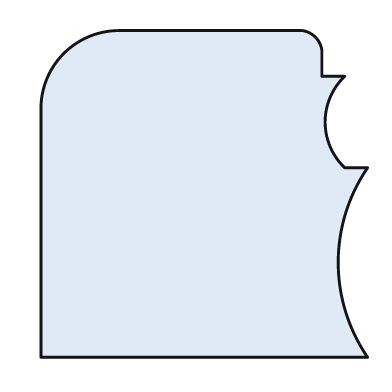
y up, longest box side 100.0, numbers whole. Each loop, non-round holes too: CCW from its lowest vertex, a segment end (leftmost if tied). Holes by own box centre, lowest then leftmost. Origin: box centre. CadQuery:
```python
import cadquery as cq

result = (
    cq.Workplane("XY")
    .moveTo(-50.0, -50.0)
    .lineTo(50.0, -50.0)
    .threePointArc((41.0, -21.0), (50.0, 8.0))
    .lineTo(43.0, 8.0)
    .threePointArc((37.0, 22.0), (43.0, 36.0))
    .lineTo(36.0, 36.0)
    .lineTo(36.0, 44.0)
    .threePointArc((34.0, 48.0), (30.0, 50.0))
    .lineTo(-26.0, 50.0)
    .threePointArc((-43.0, 43.0), (-50.0, 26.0))
    .close()
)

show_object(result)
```